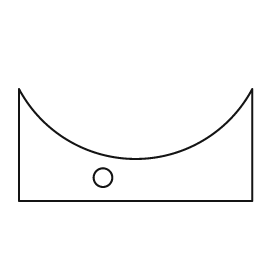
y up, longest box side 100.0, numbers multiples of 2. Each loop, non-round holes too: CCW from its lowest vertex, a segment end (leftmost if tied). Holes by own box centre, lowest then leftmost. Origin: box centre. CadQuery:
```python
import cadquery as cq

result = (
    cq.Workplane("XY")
    .moveTo(-50.0, -24.0)
    .lineTo(50.0, -24.0)
    .lineTo(50.0, 24.0)
    .threePointArc((0.0, -6.0), (-50.0, 24.0))
    .close()
    .moveTo(-14.0, -14.0)
    .circle(4.0)
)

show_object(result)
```